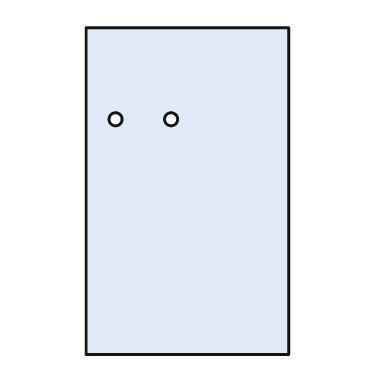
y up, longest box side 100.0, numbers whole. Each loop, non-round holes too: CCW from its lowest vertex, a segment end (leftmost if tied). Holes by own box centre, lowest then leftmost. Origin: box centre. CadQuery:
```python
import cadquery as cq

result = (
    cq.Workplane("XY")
    .moveTo(-31.0, -50.0)
    .lineTo(31.0, -50.0)
    .lineTo(31.0, 50.0)
    .lineTo(-31.0, 50.0)
    .close()
    .moveTo(-22.0, 22.0)
    .circle(2.0)
    .moveTo(-5.0, 22.0)
    .circle(2.0)
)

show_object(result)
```